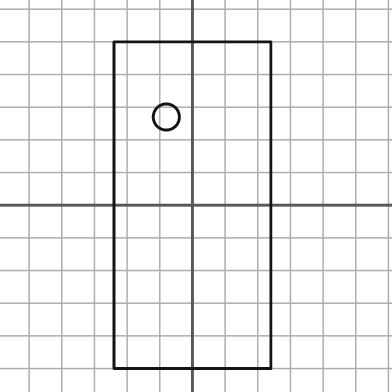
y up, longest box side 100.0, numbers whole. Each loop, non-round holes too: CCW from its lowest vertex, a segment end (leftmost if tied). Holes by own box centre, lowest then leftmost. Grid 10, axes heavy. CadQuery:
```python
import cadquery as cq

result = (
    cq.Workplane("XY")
    .moveTo(-24.0, -50.0)
    .lineTo(24.0, -50.0)
    .lineTo(24.0, 50.0)
    .lineTo(-24.0, 50.0)
    .close()
    .moveTo(-8.0, 27.0)
    .circle(4.0)
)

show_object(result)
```